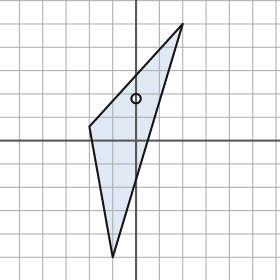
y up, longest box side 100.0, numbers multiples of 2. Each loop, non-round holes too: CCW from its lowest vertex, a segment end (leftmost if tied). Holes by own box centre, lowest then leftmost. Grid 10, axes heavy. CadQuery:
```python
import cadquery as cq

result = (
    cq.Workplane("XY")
    .moveTo(-10.0, -50.0)
    .lineTo(20.0, 50.0)
    .lineTo(-20.0, 6.0)
    .close()
    .moveTo(0.0, 18.0)
    .circle(2.0)
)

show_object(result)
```